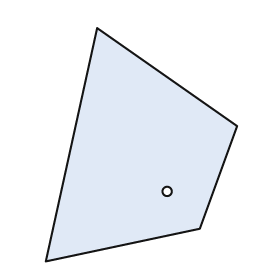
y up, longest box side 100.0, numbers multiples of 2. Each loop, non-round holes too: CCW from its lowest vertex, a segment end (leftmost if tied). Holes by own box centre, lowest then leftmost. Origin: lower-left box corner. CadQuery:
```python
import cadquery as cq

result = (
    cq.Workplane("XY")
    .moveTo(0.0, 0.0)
    .lineTo(66.0, 14.0)
    .lineTo(82.0, 58.0)
    .lineTo(22.0, 100.0)
    .close()
    .moveTo(52.0, 30.0)
    .circle(2.0)
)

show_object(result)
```